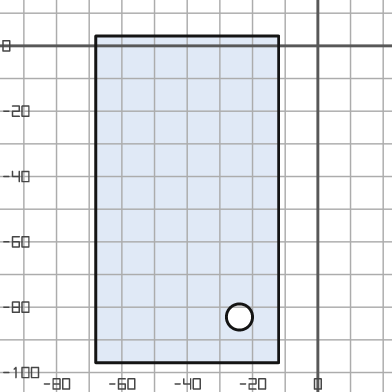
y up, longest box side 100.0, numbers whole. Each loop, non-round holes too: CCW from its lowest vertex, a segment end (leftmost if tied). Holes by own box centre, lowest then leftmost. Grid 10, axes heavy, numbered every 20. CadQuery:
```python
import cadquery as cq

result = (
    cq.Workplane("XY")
    .moveTo(-68.0, -97.0)
    .lineTo(-12.0, -97.0)
    .lineTo(-12.0, 3.0)
    .lineTo(-68.0, 3.0)
    .close()
    .moveTo(-24.0, -83.0)
    .circle(4.0)
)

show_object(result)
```